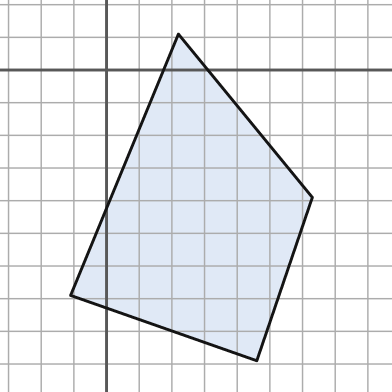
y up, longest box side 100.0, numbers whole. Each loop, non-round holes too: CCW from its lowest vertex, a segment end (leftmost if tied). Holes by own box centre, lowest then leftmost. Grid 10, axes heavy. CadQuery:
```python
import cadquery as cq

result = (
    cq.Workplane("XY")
    .moveTo(46.0, -89.0)
    .lineTo(63.0, -39.0)
    .lineTo(22.0, 11.0)
    .lineTo(-11.0, -69.0)
    .close()
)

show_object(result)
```